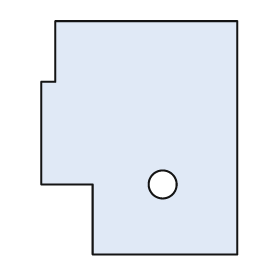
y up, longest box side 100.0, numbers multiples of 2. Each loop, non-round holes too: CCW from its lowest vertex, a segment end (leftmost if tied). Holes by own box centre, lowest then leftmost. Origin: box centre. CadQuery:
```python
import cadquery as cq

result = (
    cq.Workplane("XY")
    .moveTo(-20.0, -50.0)
    .lineTo(42.0, -50.0)
    .lineTo(42.0, 50.0)
    .lineTo(-36.0, 50.0)
    .lineTo(-36.0, 24.0)
    .lineTo(-42.0, 24.0)
    .lineTo(-42.0, -20.0)
    .lineTo(-20.0, -20.0)
    .close()
    .moveTo(10.0, -20.0)
    .circle(6.0)
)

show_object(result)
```